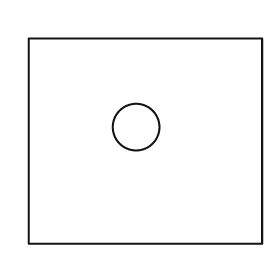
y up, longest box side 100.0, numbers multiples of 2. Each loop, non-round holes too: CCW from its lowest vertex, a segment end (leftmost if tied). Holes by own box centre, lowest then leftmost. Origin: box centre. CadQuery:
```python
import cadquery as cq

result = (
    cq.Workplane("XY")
    .moveTo(-50.0, -44.0)
    .lineTo(50.0, -44.0)
    .lineTo(50.0, 44.0)
    .lineTo(-50.0, 44.0)
    .close()
    .moveTo(-4.0, 6.0)
    .circle(10.0)
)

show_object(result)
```